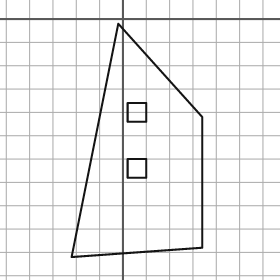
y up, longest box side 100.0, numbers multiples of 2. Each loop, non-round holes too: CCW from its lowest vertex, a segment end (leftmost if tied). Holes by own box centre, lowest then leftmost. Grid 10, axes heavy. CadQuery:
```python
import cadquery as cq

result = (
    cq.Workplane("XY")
    .moveTo(-22.0, -102.0)
    .lineTo(34.0, -98.0)
    .lineTo(34.0, -42.0)
    .lineTo(-2.0, -2.0)
    .close()
    .moveTo(2.0, -68.0)
    .lineTo(10.0, -68.0)
    .lineTo(10.0, -60.0)
    .lineTo(2.0, -60.0)
    .close()
    .moveTo(2.0, -44.0)
    .lineTo(10.0, -44.0)
    .lineTo(10.0, -36.0)
    .lineTo(2.0, -36.0)
    .close()
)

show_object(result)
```